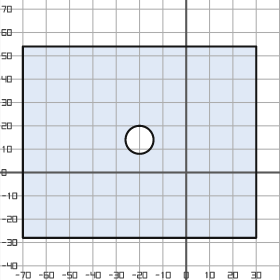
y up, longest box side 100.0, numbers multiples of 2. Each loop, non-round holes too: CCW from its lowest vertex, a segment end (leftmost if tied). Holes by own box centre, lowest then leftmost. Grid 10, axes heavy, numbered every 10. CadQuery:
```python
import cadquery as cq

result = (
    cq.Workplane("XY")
    .moveTo(-70.0, -28.0)
    .lineTo(30.0, -28.0)
    .lineTo(30.0, 54.0)
    .lineTo(-70.0, 54.0)
    .close()
    .moveTo(-20.0, 14.0)
    .circle(6.0)
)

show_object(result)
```